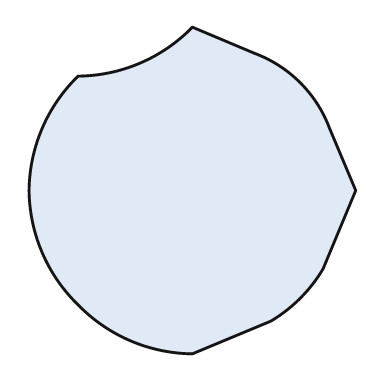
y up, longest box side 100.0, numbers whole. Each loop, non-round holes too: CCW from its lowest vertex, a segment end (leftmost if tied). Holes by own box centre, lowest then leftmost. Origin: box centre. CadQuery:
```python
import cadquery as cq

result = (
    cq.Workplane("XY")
    .moveTo(0.0, -50.0)
    .lineTo(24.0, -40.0)
    .threePointArc((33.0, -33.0), (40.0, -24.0))
    .lineTo(50.0, 0.0)
    .lineTo(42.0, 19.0)
    .threePointArc((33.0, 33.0), (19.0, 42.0))
    .lineTo(0.0, 50.0)
    .threePointArc((-16.0, 39.0), (-35.0, 35.0))
    .threePointArc((-46.0, 19.0), (-50.0, 0.0))
    .threePointArc((-46.0, -19.0), (-35.0, -35.0))
    .threePointArc((-19.0, -46.0), (0.0, -50.0))
    .close()
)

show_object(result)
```